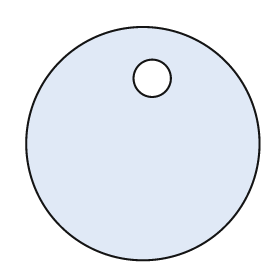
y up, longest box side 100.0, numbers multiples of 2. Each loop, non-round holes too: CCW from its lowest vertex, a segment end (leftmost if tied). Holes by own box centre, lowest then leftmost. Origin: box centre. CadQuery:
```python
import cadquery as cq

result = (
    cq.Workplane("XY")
    .moveTo(0.0, 0.0)
    .circle(50.0)
    .moveTo(4.0, 28.0)
    .circle(8.0)
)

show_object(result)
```